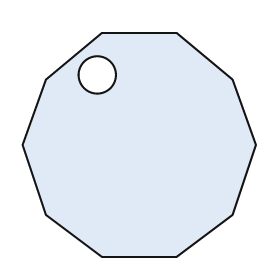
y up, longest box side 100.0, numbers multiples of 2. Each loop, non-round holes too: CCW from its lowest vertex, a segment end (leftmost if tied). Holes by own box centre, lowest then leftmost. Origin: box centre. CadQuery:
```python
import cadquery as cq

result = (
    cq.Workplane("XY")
    .moveTo(-16.0, -48.0)
    .lineTo(16.0, -48.0)
    .lineTo(40.0, -30.0)
    .lineTo(50.0, 0.0)
    .lineTo(40.0, 28.0)
    .lineTo(16.0, 48.0)
    .lineTo(-16.0, 48.0)
    .lineTo(-40.0, 28.0)
    .lineTo(-50.0, 0.0)
    .lineTo(-40.0, -30.0)
    .close()
    .moveTo(-18.0, 30.0)
    .circle(8.0)
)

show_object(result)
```